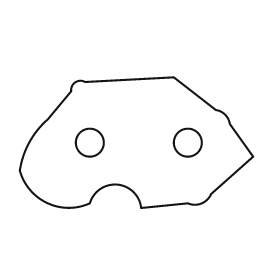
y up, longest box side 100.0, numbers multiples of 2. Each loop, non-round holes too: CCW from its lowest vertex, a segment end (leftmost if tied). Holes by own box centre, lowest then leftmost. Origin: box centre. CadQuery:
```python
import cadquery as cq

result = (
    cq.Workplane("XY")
    .moveTo(2.0, -28.0)
    .lineTo(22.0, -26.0)
    .threePointArc((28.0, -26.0), (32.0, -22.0))
    .lineTo(50.0, -6.0)
    .lineTo(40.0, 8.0)
    .threePointArc((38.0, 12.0), (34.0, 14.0))
    .lineTo(16.0, 28.0)
    .lineTo(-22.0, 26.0)
    .threePointArc((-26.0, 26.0), (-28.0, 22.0))
    .lineTo(-38.0, 10.0)
    .threePointArc((-46.0, 0.0), (-50.0, -12.0))
    .threePointArc((-38.0, -26.0), (-20.0, -26.0))
    .threePointArc((-8.0, -18.0), (2.0, -28.0))
    .close()
    .moveTo(-20.0, 0.0)
    .circle(6.0)
    .moveTo(22.0, 0.0)
    .circle(6.0)
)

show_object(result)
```